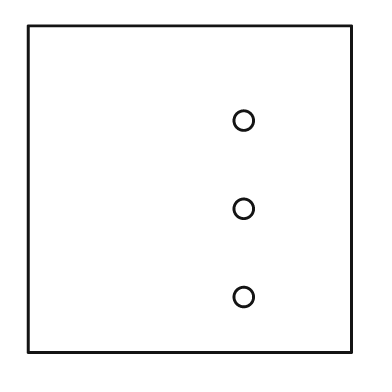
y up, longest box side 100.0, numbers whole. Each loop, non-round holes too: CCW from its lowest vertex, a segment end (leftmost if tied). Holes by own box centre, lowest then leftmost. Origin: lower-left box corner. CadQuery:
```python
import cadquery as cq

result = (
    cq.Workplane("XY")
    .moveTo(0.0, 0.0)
    .lineTo(99.0, 0.0)
    .lineTo(99.0, 100.0)
    .lineTo(0.0, 100.0)
    .close()
    .moveTo(66.0, 17.0)
    .circle(3.0)
    .moveTo(66.0, 44.0)
    .circle(3.0)
    .moveTo(66.0, 71.0)
    .circle(3.0)
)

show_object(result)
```